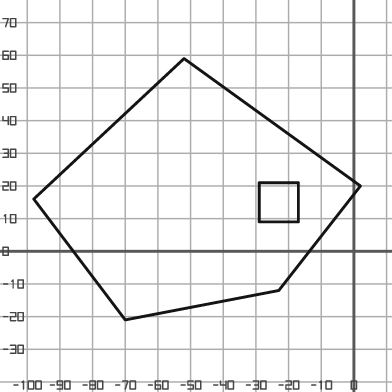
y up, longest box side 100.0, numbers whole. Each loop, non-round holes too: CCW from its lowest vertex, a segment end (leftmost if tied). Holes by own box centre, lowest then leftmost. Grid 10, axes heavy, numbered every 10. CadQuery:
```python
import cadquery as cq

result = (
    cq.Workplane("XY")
    .moveTo(-70.0, -21.0)
    .lineTo(-23.0, -12.0)
    .lineTo(2.0, 20.0)
    .lineTo(-52.0, 59.0)
    .lineTo(-98.0, 16.0)
    .close()
    .moveTo(-29.0, 9.0)
    .lineTo(-17.0, 9.0)
    .lineTo(-17.0, 21.0)
    .lineTo(-29.0, 21.0)
    .close()
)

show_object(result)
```